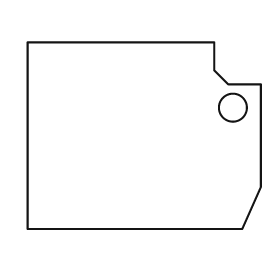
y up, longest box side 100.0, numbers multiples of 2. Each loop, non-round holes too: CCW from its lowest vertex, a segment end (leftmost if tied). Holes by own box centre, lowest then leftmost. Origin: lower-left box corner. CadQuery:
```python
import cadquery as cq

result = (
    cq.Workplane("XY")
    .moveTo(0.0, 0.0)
    .lineTo(92.0, 0.0)
    .lineTo(100.0, 18.0)
    .lineTo(100.0, 62.0)
    .lineTo(86.0, 62.0)
    .lineTo(80.0, 68.0)
    .lineTo(80.0, 80.0)
    .lineTo(0.0, 80.0)
    .close()
    .moveTo(88.0, 52.0)
    .circle(6.0)
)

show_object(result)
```